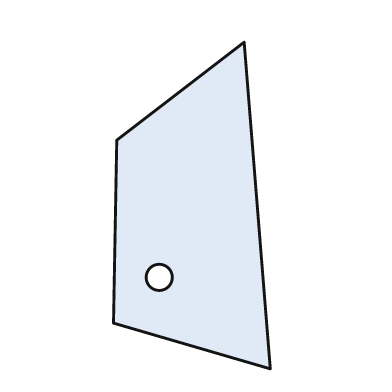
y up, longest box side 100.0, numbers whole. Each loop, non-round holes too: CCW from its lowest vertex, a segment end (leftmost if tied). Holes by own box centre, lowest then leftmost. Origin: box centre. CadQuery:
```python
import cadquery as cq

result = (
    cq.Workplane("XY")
    .moveTo(24.0, -50.0)
    .lineTo(16.0, 50.0)
    .lineTo(-23.0, 20.0)
    .lineTo(-24.0, -36.0)
    .close()
    .moveTo(-10.0, -22.0)
    .circle(4.0)
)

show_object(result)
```